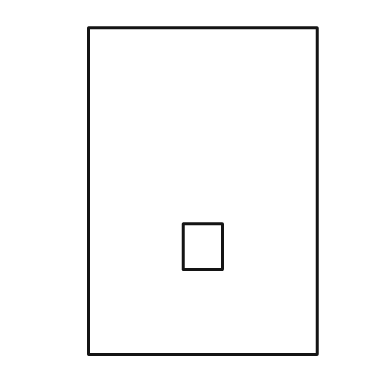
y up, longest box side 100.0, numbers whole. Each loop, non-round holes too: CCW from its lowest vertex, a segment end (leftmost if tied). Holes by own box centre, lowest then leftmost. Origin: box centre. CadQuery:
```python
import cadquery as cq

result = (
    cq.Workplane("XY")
    .moveTo(-35.0, -50.0)
    .lineTo(35.0, -50.0)
    .lineTo(35.0, 50.0)
    .lineTo(-35.0, 50.0)
    .close()
    .moveTo(-6.0, -24.0)
    .lineTo(6.0, -24.0)
    .lineTo(6.0, -10.0)
    .lineTo(-6.0, -10.0)
    .close()
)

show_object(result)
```